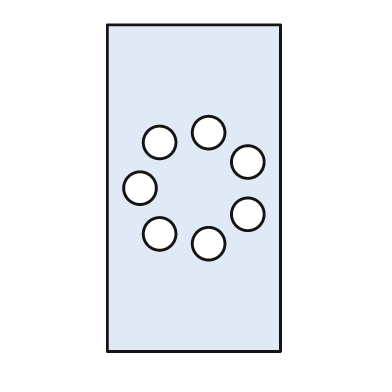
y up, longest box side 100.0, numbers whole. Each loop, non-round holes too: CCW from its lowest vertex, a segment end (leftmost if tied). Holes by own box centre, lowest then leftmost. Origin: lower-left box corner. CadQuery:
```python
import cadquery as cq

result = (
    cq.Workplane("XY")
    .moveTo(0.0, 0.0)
    .lineTo(53.0, 0.0)
    .lineTo(53.0, 100.0)
    .lineTo(0.0, 100.0)
    .close()
    .moveTo(31.0, 33.0)
    .circle(5.0)
    .moveTo(16.0, 36.0)
    .circle(5.0)
    .moveTo(43.0, 42.0)
    .circle(5.0)
    .moveTo(10.0, 50.0)
    .circle(5.0)
    .moveTo(43.0, 58.0)
    .circle(5.0)
    .moveTo(16.0, 64.0)
    .circle(5.0)
    .moveTo(31.0, 67.0)
    .circle(5.0)
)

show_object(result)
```